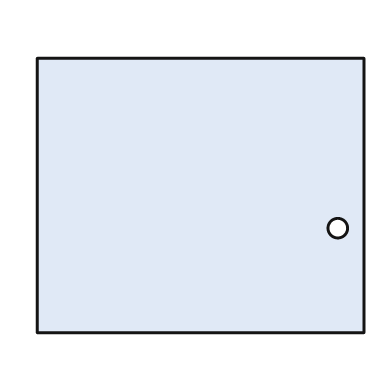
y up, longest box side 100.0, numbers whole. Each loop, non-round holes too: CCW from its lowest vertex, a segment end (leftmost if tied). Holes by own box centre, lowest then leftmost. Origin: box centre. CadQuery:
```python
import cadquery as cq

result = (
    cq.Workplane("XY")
    .moveTo(-50.0, -42.0)
    .lineTo(50.0, -42.0)
    .lineTo(50.0, 42.0)
    .lineTo(-50.0, 42.0)
    .close()
    .moveTo(42.0, -10.0)
    .circle(3.0)
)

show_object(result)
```